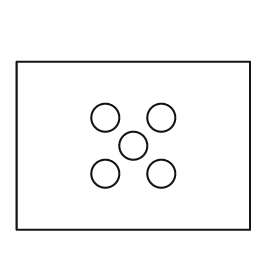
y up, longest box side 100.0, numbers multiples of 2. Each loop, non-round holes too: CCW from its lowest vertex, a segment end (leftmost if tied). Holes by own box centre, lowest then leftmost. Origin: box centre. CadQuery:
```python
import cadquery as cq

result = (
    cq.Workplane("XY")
    .moveTo(-50.0, -36.0)
    .lineTo(50.0, -36.0)
    .lineTo(50.0, 36.0)
    .lineTo(-50.0, 36.0)
    .close()
    .moveTo(-12.0, -12.0)
    .circle(6.0)
    .moveTo(12.0, -12.0)
    .circle(6.0)
    .moveTo(0.0, 0.0)
    .circle(6.0)
    .moveTo(-12.0, 12.0)
    .circle(6.0)
    .moveTo(12.0, 12.0)
    .circle(6.0)
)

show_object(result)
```